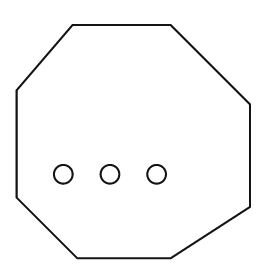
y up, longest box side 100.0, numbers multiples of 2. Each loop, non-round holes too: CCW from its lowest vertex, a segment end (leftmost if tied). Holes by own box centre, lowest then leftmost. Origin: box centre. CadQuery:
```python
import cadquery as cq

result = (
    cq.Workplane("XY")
    .moveTo(-24.0, -50.0)
    .lineTo(16.0, -50.0)
    .lineTo(50.0, -28.0)
    .lineTo(50.0, 16.0)
    .lineTo(16.0, 50.0)
    .lineTo(-26.0, 50.0)
    .lineTo(-50.0, 22.0)
    .lineTo(-50.0, -24.0)
    .close()
    .moveTo(-30.0, -14.0)
    .circle(4.0)
    .moveTo(-10.0, -14.0)
    .circle(4.0)
    .moveTo(10.0, -14.0)
    .circle(4.0)
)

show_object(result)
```